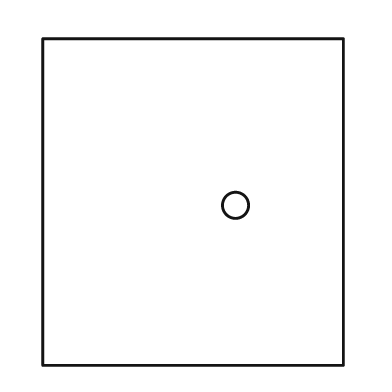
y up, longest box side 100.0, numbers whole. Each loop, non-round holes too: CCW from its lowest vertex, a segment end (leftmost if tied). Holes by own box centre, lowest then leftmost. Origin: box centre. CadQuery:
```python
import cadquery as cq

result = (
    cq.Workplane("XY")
    .moveTo(-46.0, -50.0)
    .lineTo(46.0, -50.0)
    .lineTo(46.0, 50.0)
    .lineTo(-46.0, 50.0)
    .close()
    .moveTo(13.0, -1.0)
    .circle(4.0)
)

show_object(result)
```